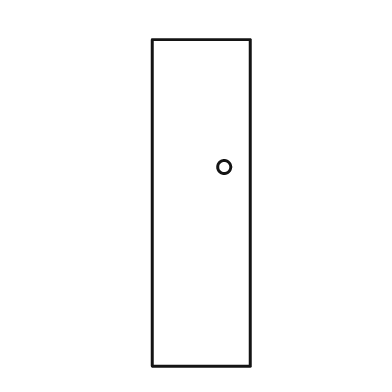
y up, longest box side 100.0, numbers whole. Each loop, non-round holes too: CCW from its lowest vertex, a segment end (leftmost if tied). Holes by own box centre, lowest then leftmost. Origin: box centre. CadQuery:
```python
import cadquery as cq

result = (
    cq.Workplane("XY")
    .moveTo(-15.0, -50.0)
    .lineTo(15.0, -50.0)
    .lineTo(15.0, 50.0)
    .lineTo(-15.0, 50.0)
    .close()
    .moveTo(7.0, 11.0)
    .circle(2.0)
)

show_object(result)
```